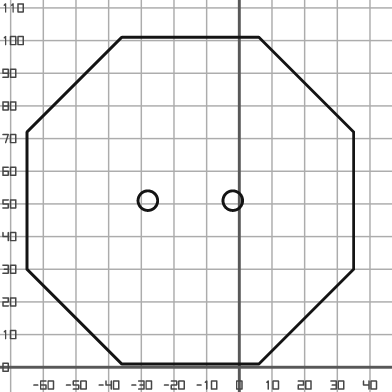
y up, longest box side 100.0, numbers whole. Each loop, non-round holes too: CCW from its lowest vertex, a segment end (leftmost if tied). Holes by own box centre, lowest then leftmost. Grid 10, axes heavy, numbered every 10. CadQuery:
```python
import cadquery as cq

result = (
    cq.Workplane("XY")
    .moveTo(-36.0, 1.0)
    .lineTo(6.0, 1.0)
    .lineTo(35.0, 30.0)
    .lineTo(35.0, 72.0)
    .lineTo(6.0, 101.0)
    .lineTo(-36.0, 101.0)
    .lineTo(-65.0, 72.0)
    .lineTo(-65.0, 30.0)
    .close()
    .moveTo(-28.0, 51.0)
    .circle(3.0)
    .moveTo(-2.0, 51.0)
    .circle(3.0)
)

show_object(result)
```